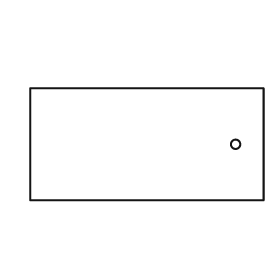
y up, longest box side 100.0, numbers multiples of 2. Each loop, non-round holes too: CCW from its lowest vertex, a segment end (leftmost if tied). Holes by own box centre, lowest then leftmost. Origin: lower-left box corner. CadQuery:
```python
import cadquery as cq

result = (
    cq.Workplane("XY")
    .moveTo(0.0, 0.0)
    .lineTo(100.0, 0.0)
    .lineTo(100.0, 48.0)
    .lineTo(0.0, 48.0)
    .close()
    .moveTo(88.0, 24.0)
    .circle(2.0)
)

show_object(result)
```